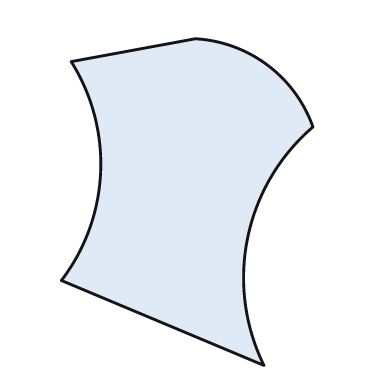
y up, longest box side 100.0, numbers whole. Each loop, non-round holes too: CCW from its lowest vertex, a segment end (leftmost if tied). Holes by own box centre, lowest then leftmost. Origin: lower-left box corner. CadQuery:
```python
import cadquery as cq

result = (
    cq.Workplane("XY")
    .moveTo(62.0, 0.0)
    .threePointArc((57.0, 39.0), (77.0, 73.0))
    .threePointArc((63.0, 92.0), (41.0, 100.0))
    .lineTo(3.0, 93.0)
    .threePointArc((12.0, 59.0), (0.0, 26.0))
    .close()
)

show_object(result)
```